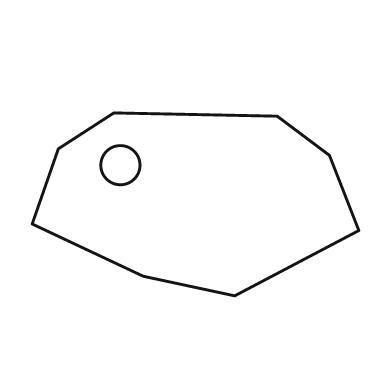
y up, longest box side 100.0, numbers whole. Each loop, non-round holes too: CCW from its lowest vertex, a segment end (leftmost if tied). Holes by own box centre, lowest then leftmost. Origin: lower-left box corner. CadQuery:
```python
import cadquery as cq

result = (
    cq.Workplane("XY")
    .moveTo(62.0, 0.0)
    .lineTo(100.0, 20.0)
    .lineTo(91.0, 43.0)
    .lineTo(75.0, 55.0)
    .lineTo(25.0, 56.0)
    .lineTo(8.0, 45.0)
    .lineTo(0.0, 22.0)
    .lineTo(34.0, 6.0)
    .close()
    .moveTo(27.0, 40.0)
    .circle(6.0)
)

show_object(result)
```